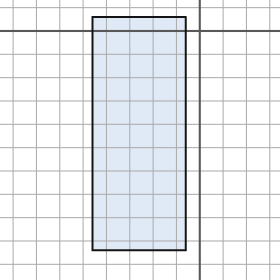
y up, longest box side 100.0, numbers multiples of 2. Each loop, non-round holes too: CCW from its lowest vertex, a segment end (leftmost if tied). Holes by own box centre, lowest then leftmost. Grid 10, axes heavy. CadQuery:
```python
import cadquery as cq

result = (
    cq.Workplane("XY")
    .moveTo(-46.0, -94.0)
    .lineTo(-6.0, -94.0)
    .lineTo(-6.0, 6.0)
    .lineTo(-46.0, 6.0)
    .close()
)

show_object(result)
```